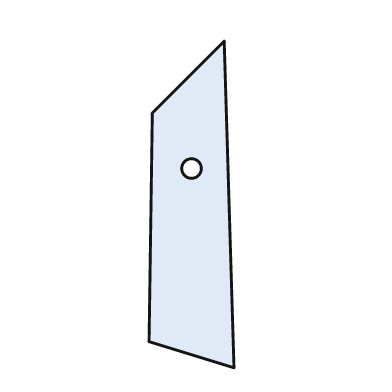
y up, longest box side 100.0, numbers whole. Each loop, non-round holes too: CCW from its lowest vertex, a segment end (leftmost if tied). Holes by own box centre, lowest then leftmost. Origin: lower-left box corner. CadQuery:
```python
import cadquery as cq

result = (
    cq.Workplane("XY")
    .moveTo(26.0, 0.0)
    .lineTo(23.0, 100.0)
    .lineTo(1.0, 78.0)
    .lineTo(0.0, 8.0)
    .close()
    .moveTo(13.0, 61.0)
    .circle(3.0)
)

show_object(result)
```